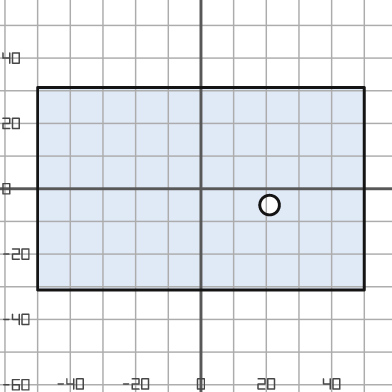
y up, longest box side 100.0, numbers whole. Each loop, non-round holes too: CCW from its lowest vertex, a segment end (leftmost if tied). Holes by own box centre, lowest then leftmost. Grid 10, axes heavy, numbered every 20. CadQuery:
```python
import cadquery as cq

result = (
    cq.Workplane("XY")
    .moveTo(-50.0, -31.0)
    .lineTo(50.0, -31.0)
    .lineTo(50.0, 31.0)
    .lineTo(-50.0, 31.0)
    .close()
    .moveTo(21.0, -5.0)
    .circle(3.0)
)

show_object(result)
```